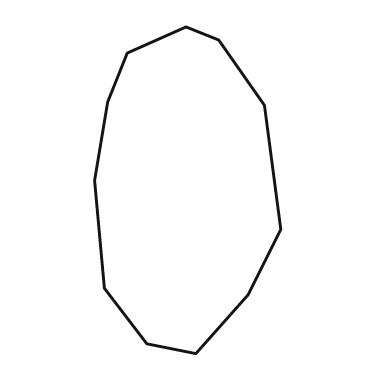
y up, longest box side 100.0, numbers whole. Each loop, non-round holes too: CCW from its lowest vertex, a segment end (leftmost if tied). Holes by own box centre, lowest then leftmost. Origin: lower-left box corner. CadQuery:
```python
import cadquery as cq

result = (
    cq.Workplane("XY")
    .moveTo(31.0, 0.0)
    .lineTo(47.0, 18.0)
    .lineTo(57.0, 38.0)
    .lineTo(52.0, 76.0)
    .lineTo(38.0, 96.0)
    .lineTo(28.0, 100.0)
    .lineTo(10.0, 92.0)
    .lineTo(4.0, 77.0)
    .lineTo(0.0, 53.0)
    .lineTo(3.0, 20.0)
    .lineTo(16.0, 3.0)
    .close()
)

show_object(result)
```